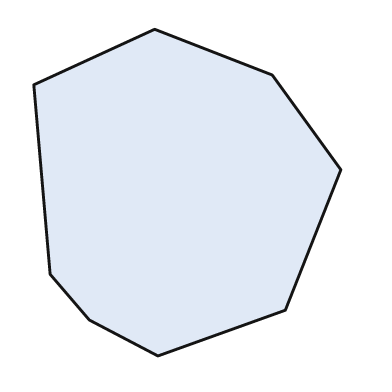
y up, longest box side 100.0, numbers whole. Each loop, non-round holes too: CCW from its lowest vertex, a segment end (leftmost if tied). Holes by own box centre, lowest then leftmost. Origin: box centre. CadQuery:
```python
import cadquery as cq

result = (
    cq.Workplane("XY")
    .moveTo(-9.0, -50.0)
    .lineTo(30.0, -36.0)
    .lineTo(47.0, 7.0)
    .lineTo(26.0, 36.0)
    .lineTo(-10.0, 50.0)
    .lineTo(-47.0, 33.0)
    .lineTo(-42.0, -25.0)
    .lineTo(-30.0, -39.0)
    .close()
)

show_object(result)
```